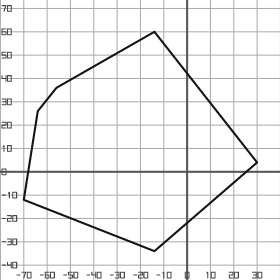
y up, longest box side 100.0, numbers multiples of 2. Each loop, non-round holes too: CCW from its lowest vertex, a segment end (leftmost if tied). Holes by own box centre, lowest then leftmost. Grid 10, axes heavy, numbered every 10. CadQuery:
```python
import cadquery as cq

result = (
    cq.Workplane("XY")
    .moveTo(-14.0, -34.0)
    .lineTo(30.0, 4.0)
    .lineTo(-14.0, 60.0)
    .lineTo(-56.0, 36.0)
    .lineTo(-64.0, 26.0)
    .lineTo(-70.0, -12.0)
    .close()
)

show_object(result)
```